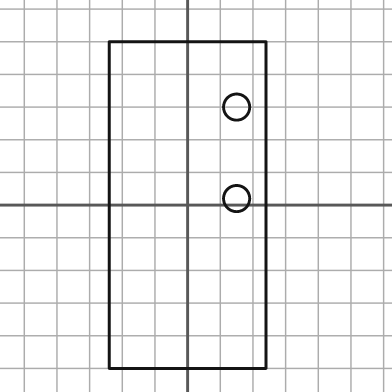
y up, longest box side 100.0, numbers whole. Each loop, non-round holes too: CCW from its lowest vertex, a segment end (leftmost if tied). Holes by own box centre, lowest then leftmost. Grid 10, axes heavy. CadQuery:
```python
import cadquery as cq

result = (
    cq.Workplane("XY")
    .moveTo(-24.0, -50.0)
    .lineTo(24.0, -50.0)
    .lineTo(24.0, 50.0)
    .lineTo(-24.0, 50.0)
    .close()
    .moveTo(15.0, 2.0)
    .circle(4.0)
    .moveTo(15.0, 30.0)
    .circle(4.0)
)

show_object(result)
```